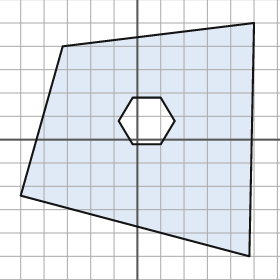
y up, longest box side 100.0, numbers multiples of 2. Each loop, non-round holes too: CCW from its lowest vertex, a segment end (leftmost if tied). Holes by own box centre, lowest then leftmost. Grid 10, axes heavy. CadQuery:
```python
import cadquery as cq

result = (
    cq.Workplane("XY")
    .moveTo(48.0, -50.0)
    .lineTo(50.0, 50.0)
    .lineTo(-32.0, 40.0)
    .lineTo(-50.0, -24.0)
    .close()
    .moveTo(-2.0, -2.0)
    .lineTo(10.0, -2.0)
    .lineTo(16.0, 8.0)
    .lineTo(10.0, 18.0)
    .lineTo(-2.0, 18.0)
    .lineTo(-8.0, 8.0)
    .close()
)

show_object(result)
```